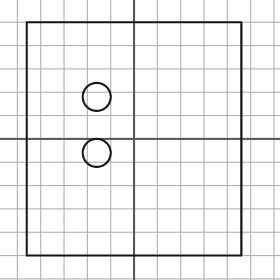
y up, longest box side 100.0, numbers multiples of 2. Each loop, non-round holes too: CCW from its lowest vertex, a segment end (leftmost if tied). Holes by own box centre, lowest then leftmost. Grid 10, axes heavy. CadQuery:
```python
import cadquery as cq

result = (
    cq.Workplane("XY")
    .moveTo(-46.0, -50.0)
    .lineTo(46.0, -50.0)
    .lineTo(46.0, 50.0)
    .lineTo(-46.0, 50.0)
    .close()
    .moveTo(-16.0, -6.0)
    .circle(6.0)
    .moveTo(-16.0, 18.0)
    .circle(6.0)
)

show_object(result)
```